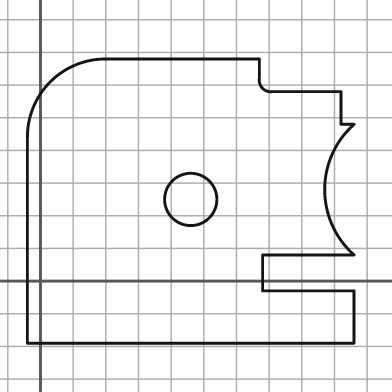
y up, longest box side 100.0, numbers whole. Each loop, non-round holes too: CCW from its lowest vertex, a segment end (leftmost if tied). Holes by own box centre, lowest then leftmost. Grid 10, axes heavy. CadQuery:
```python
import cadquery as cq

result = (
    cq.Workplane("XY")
    .moveTo(-4.0, -19.0)
    .lineTo(96.0, -19.0)
    .lineTo(96.0, -3.0)
    .lineTo(68.0, -3.0)
    .lineTo(68.0, 8.0)
    .lineTo(96.0, 8.0)
    .threePointArc((87.0, 28.0), (96.0, 48.0))
    .lineTo(92.0, 48.0)
    .lineTo(92.0, 58.0)
    .lineTo(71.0, 58.0)
    .threePointArc((68.0, 59.0), (67.0, 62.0))
    .lineTo(67.0, 68.0)
    .lineTo(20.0, 68.0)
    .threePointArc((3.0, 61.0), (-4.0, 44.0))
    .close()
    .moveTo(46.0, 25.0)
    .circle(8.0)
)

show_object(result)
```